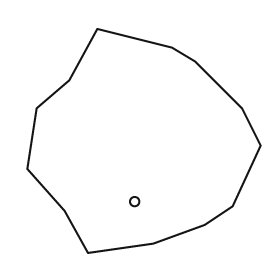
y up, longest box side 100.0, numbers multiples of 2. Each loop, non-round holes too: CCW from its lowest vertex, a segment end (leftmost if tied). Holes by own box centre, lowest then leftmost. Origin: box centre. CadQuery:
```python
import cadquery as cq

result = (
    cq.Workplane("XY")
    .moveTo(-24.0, -48.0)
    .lineTo(4.0, -44.0)
    .lineTo(26.0, -36.0)
    .lineTo(38.0, -28.0)
    .lineTo(50.0, -2.0)
    .lineTo(42.0, 14.0)
    .lineTo(22.0, 34.0)
    .lineTo(12.0, 40.0)
    .lineTo(-20.0, 48.0)
    .lineTo(-32.0, 26.0)
    .lineTo(-46.0, 14.0)
    .lineTo(-50.0, -12.0)
    .lineTo(-34.0, -30.0)
    .close()
    .moveTo(-4.0, -26.0)
    .circle(2.0)
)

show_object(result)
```